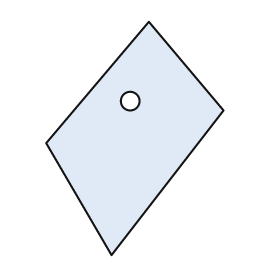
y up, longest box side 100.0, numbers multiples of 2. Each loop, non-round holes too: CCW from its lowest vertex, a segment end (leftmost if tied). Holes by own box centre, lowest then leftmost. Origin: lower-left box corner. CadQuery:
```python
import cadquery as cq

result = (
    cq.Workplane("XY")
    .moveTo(28.0, 0.0)
    .lineTo(76.0, 62.0)
    .lineTo(44.0, 100.0)
    .lineTo(0.0, 48.0)
    .close()
    .moveTo(36.0, 66.0)
    .circle(4.0)
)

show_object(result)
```